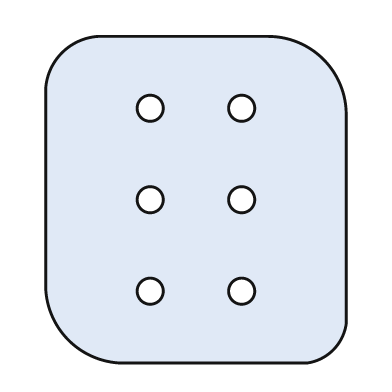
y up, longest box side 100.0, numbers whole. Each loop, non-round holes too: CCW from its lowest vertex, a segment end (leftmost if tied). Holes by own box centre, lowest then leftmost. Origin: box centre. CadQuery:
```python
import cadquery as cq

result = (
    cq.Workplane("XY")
    .moveTo(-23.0, -50.0)
    .lineTo(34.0, -50.0)
    .threePointArc((42.0, -46.0), (46.0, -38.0))
    .lineTo(46.0, 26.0)
    .threePointArc((39.0, 43.0), (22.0, 50.0))
    .lineTo(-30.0, 50.0)
    .threePointArc((-41.0, 45.0), (-46.0, 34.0))
    .lineTo(-46.0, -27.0)
    .threePointArc((-39.0, -43.0), (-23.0, -50.0))
    .close()
    .moveTo(-14.0, -28.0)
    .circle(4.0)
    .moveTo(14.0, -28.0)
    .circle(4.0)
    .moveTo(-14.0, 0.0)
    .circle(4.0)
    .moveTo(14.0, 0.0)
    .circle(4.0)
    .moveTo(-14.0, 28.0)
    .circle(4.0)
    .moveTo(14.0, 28.0)
    .circle(4.0)
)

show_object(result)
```